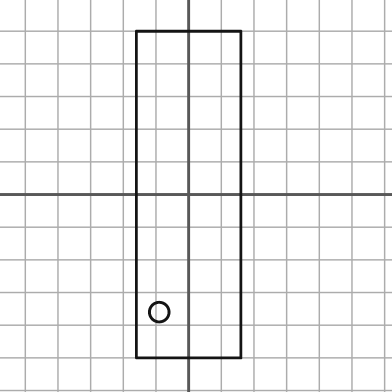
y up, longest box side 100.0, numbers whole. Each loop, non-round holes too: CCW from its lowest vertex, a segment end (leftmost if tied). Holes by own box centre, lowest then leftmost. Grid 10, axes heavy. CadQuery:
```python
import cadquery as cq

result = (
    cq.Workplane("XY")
    .moveTo(-16.0, -50.0)
    .lineTo(16.0, -50.0)
    .lineTo(16.0, 50.0)
    .lineTo(-16.0, 50.0)
    .close()
    .moveTo(-9.0, -36.0)
    .circle(3.0)
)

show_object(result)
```